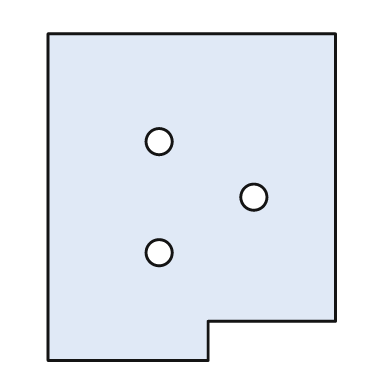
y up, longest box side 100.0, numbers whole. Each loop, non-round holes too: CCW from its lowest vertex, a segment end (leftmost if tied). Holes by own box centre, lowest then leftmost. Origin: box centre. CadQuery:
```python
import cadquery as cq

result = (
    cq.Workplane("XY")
    .moveTo(-44.0, -50.0)
    .lineTo(5.0, -50.0)
    .lineTo(5.0, -38.0)
    .lineTo(44.0, -38.0)
    .lineTo(44.0, 50.0)
    .lineTo(-44.0, 50.0)
    .close()
    .moveTo(-10.0, -17.0)
    .circle(4.0)
    .moveTo(19.0, 0.0)
    .circle(4.0)
    .moveTo(-10.0, 17.0)
    .circle(4.0)
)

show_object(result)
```